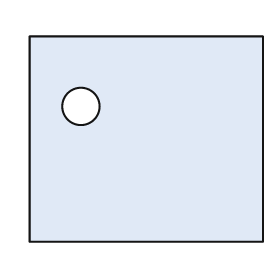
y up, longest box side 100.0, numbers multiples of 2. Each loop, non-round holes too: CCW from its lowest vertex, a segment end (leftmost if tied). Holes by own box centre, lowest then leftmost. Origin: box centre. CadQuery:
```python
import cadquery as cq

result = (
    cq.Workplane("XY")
    .moveTo(-50.0, -44.0)
    .lineTo(50.0, -44.0)
    .lineTo(50.0, 44.0)
    .lineTo(-50.0, 44.0)
    .close()
    .moveTo(-28.0, 14.0)
    .circle(8.0)
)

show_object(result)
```